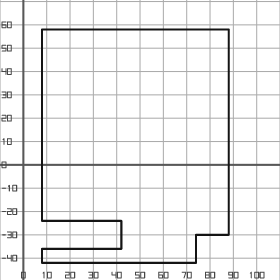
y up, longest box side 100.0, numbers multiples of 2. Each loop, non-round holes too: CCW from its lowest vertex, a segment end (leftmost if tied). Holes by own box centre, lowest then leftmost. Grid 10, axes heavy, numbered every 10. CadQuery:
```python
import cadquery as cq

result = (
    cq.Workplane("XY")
    .moveTo(8.0, -42.0)
    .lineTo(74.0, -42.0)
    .lineTo(74.0, -30.0)
    .lineTo(88.0, -30.0)
    .lineTo(88.0, 58.0)
    .lineTo(8.0, 58.0)
    .lineTo(8.0, -24.0)
    .lineTo(42.0, -24.0)
    .lineTo(42.0, -36.0)
    .lineTo(8.0, -36.0)
    .close()
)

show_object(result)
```